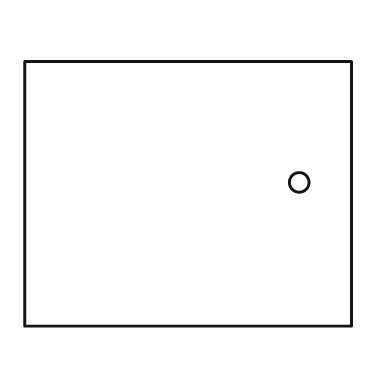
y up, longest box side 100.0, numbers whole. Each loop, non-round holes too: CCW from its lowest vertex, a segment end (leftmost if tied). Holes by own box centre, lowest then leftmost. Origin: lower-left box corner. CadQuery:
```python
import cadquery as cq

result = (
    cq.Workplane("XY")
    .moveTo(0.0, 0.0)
    .lineTo(100.0, 0.0)
    .lineTo(100.0, 81.0)
    .lineTo(0.0, 81.0)
    .close()
    .moveTo(84.0, 44.0)
    .circle(3.0)
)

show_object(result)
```